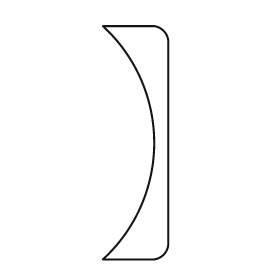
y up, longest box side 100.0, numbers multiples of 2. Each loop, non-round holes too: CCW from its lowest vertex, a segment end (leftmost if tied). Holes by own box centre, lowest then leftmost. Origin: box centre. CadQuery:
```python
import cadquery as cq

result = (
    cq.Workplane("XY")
    .moveTo(-14.0, -50.0)
    .lineTo(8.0, -50.0)
    .threePointArc((12.0, -48.0), (14.0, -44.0))
    .lineTo(14.0, 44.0)
    .threePointArc((12.0, 48.0), (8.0, 50.0))
    .lineTo(-14.0, 50.0)
    .threePointArc((8.0, 0.0), (-14.0, -50.0))
    .close()
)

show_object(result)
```